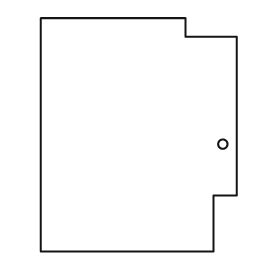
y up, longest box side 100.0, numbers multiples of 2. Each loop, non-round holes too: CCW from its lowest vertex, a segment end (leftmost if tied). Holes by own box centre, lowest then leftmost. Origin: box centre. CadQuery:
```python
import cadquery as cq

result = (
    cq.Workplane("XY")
    .moveTo(-42.0, -50.0)
    .lineTo(32.0, -50.0)
    .lineTo(32.0, -26.0)
    .lineTo(42.0, -26.0)
    .lineTo(42.0, 42.0)
    .lineTo(20.0, 42.0)
    .lineTo(20.0, 50.0)
    .lineTo(-42.0, 50.0)
    .close()
    .moveTo(36.0, -4.0)
    .circle(2.0)
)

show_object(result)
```